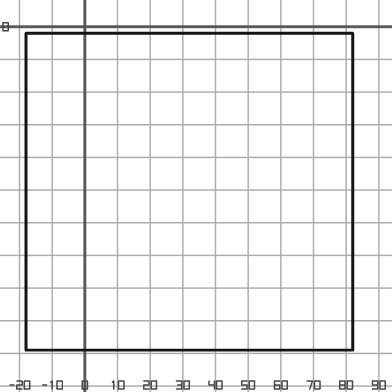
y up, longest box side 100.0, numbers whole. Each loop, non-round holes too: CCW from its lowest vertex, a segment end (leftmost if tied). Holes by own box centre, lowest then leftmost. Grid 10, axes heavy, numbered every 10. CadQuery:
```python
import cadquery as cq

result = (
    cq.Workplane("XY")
    .moveTo(-18.0, -99.0)
    .lineTo(82.0, -99.0)
    .lineTo(82.0, -2.0)
    .lineTo(-18.0, -2.0)
    .close()
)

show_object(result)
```